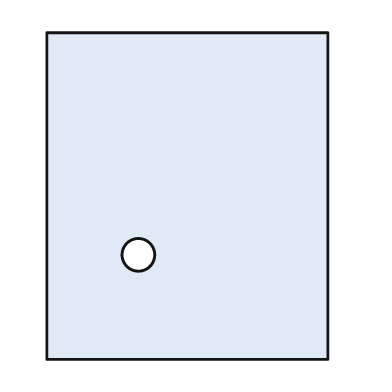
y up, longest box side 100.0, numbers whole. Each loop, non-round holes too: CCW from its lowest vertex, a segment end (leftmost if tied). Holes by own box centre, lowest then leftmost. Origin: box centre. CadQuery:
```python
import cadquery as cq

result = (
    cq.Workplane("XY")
    .moveTo(-43.0, -50.0)
    .lineTo(43.0, -50.0)
    .lineTo(43.0, 50.0)
    .lineTo(-43.0, 50.0)
    .close()
    .moveTo(-15.0, -18.0)
    .circle(5.0)
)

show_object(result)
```